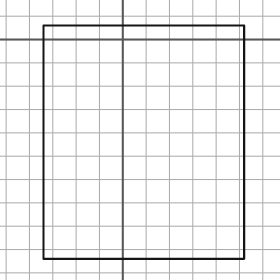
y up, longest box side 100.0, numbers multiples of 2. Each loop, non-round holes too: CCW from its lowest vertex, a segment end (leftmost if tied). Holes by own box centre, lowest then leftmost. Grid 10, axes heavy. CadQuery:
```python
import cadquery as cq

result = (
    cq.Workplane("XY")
    .moveTo(-34.0, -94.0)
    .lineTo(52.0, -94.0)
    .lineTo(52.0, 6.0)
    .lineTo(-34.0, 6.0)
    .close()
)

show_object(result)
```